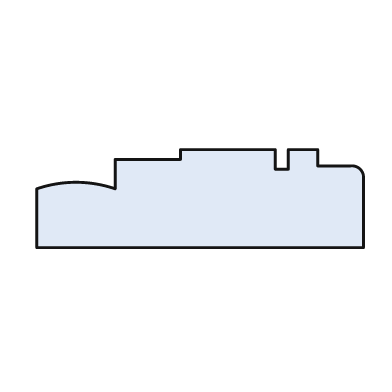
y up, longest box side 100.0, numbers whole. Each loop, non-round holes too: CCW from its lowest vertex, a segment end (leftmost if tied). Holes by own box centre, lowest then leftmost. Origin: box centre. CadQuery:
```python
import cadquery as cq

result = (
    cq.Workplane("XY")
    .moveTo(-50.0, -15.0)
    .lineTo(50.0, -15.0)
    .lineTo(50.0, 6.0)
    .threePointArc((49.0, 9.0), (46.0, 10.0))
    .lineTo(36.0, 10.0)
    .lineTo(36.0, 15.0)
    .lineTo(27.0, 15.0)
    .lineTo(27.0, 9.0)
    .lineTo(23.0, 9.0)
    .lineTo(23.0, 15.0)
    .lineTo(-6.0, 15.0)
    .lineTo(-6.0, 12.0)
    .lineTo(-26.0, 12.0)
    .lineTo(-26.0, 3.0)
    .threePointArc((-38.0, 5.0), (-50.0, 3.0))
    .close()
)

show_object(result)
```